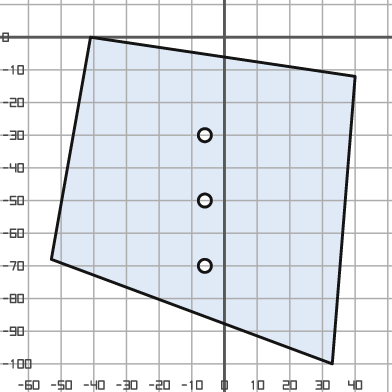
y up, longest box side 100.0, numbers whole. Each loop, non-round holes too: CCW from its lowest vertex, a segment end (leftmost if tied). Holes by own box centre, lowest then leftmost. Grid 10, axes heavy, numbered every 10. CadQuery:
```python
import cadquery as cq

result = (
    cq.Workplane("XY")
    .moveTo(33.0, -100.0)
    .lineTo(40.0, -12.0)
    .lineTo(-41.0, 0.0)
    .lineTo(-53.0, -68.0)
    .close()
    .moveTo(-6.0, -70.0)
    .circle(2.0)
    .moveTo(-6.0, -50.0)
    .circle(2.0)
    .moveTo(-6.0, -30.0)
    .circle(2.0)
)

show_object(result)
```